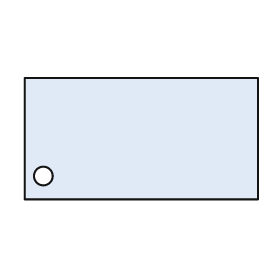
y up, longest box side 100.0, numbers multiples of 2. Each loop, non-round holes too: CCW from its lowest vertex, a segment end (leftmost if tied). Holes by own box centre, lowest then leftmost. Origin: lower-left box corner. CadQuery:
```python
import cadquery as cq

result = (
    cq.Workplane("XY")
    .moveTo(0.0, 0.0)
    .lineTo(100.0, 0.0)
    .lineTo(100.0, 52.0)
    .lineTo(0.0, 52.0)
    .close()
    .moveTo(8.0, 10.0)
    .circle(4.0)
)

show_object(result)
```